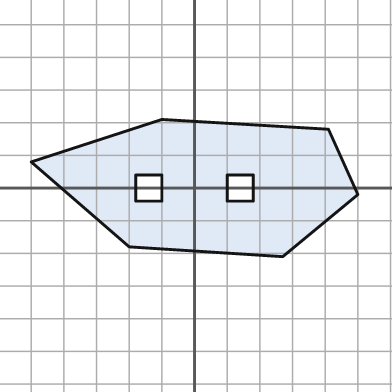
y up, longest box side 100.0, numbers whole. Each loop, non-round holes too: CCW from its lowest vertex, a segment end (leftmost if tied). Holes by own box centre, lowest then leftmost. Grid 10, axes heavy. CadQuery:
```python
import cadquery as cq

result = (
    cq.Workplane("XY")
    .moveTo(27.0, -21.0)
    .lineTo(50.0, -2.0)
    .lineTo(41.0, 18.0)
    .lineTo(-10.0, 21.0)
    .lineTo(-50.0, 8.0)
    .lineTo(-20.0, -18.0)
    .close()
    .moveTo(-18.0, -4.0)
    .lineTo(-10.0, -4.0)
    .lineTo(-10.0, 4.0)
    .lineTo(-18.0, 4.0)
    .close()
    .moveTo(10.0, -4.0)
    .lineTo(18.0, -4.0)
    .lineTo(18.0, 4.0)
    .lineTo(10.0, 4.0)
    .close()
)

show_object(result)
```